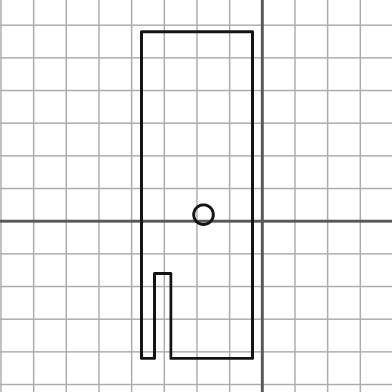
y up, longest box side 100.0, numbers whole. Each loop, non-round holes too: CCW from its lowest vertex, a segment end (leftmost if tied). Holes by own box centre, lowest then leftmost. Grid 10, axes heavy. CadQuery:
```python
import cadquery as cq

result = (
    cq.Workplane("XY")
    .moveTo(-37.0, -42.0)
    .lineTo(-33.0, -42.0)
    .lineTo(-33.0, -16.0)
    .lineTo(-28.0, -16.0)
    .lineTo(-28.0, -42.0)
    .lineTo(-3.0, -42.0)
    .lineTo(-3.0, 58.0)
    .lineTo(-37.0, 58.0)
    .close()
    .moveTo(-18.0, 2.0)
    .circle(3.0)
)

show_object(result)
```